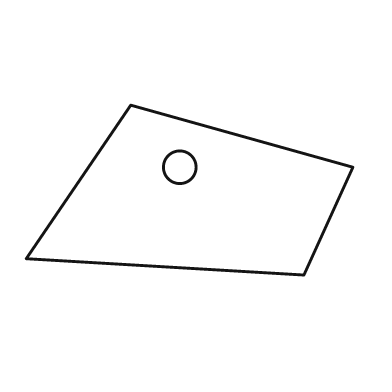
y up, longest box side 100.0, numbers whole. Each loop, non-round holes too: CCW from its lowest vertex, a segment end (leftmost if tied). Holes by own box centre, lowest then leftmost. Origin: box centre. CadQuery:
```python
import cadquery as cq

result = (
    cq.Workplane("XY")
    .moveTo(35.0, -26.0)
    .lineTo(50.0, 7.0)
    .lineTo(-18.0, 26.0)
    .lineTo(-50.0, -21.0)
    .close()
    .moveTo(-3.0, 7.0)
    .circle(5.0)
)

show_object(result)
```